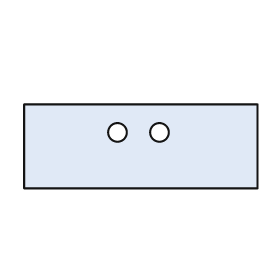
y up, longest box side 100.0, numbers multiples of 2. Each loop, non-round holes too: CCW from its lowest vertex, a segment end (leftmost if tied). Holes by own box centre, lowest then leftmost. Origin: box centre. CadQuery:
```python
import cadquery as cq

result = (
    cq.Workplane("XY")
    .moveTo(-50.0, -18.0)
    .lineTo(50.0, -18.0)
    .lineTo(50.0, 18.0)
    .lineTo(-50.0, 18.0)
    .close()
    .moveTo(-10.0, 6.0)
    .circle(4.0)
    .moveTo(8.0, 6.0)
    .circle(4.0)
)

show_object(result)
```